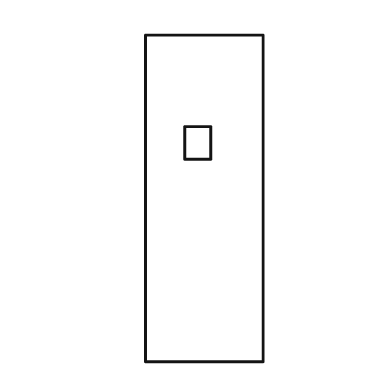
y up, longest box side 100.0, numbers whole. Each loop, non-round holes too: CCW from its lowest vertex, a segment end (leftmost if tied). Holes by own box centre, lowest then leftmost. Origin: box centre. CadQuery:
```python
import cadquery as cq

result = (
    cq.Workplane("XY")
    .moveTo(-18.0, -50.0)
    .lineTo(18.0, -50.0)
    .lineTo(18.0, 50.0)
    .lineTo(-18.0, 50.0)
    .close()
    .moveTo(-6.0, 12.0)
    .lineTo(2.0, 12.0)
    .lineTo(2.0, 22.0)
    .lineTo(-6.0, 22.0)
    .close()
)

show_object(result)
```